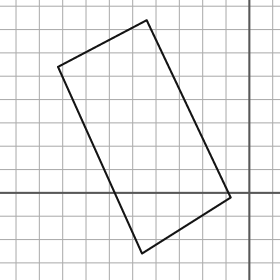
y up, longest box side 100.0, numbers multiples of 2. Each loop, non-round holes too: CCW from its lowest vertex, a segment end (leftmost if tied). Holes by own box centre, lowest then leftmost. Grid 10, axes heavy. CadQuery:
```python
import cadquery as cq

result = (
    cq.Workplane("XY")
    .moveTo(-46.0, -26.0)
    .lineTo(-8.0, -2.0)
    .lineTo(-44.0, 74.0)
    .lineTo(-82.0, 54.0)
    .close()
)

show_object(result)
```